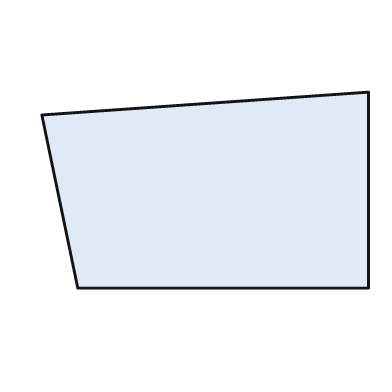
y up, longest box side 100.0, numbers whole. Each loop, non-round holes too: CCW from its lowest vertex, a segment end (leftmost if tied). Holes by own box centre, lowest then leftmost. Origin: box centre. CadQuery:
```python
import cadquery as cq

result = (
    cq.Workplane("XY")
    .moveTo(-39.0, -30.0)
    .lineTo(50.0, -30.0)
    .lineTo(50.0, 30.0)
    .lineTo(-50.0, 23.0)
    .close()
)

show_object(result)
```